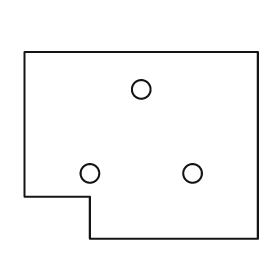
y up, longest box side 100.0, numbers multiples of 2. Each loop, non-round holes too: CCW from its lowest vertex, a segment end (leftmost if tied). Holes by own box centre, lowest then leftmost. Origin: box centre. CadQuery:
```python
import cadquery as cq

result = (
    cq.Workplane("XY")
    .moveTo(-22.0, -40.0)
    .lineTo(50.0, -40.0)
    .lineTo(50.0, 40.0)
    .lineTo(-50.0, 40.0)
    .lineTo(-50.0, -22.0)
    .lineTo(-22.0, -22.0)
    .close()
    .moveTo(-22.0, -12.0)
    .circle(4.0)
    .moveTo(22.0, -12.0)
    .circle(4.0)
    .moveTo(0.0, 24.0)
    .circle(4.0)
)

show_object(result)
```